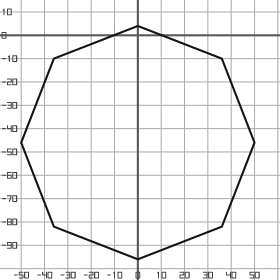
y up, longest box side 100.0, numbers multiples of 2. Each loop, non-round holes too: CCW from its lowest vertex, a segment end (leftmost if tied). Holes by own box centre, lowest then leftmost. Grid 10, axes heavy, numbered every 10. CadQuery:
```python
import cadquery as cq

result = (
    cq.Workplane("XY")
    .moveTo(0.0, -96.0)
    .lineTo(36.0, -82.0)
    .lineTo(50.0, -46.0)
    .lineTo(36.0, -10.0)
    .lineTo(0.0, 4.0)
    .lineTo(-36.0, -10.0)
    .lineTo(-50.0, -46.0)
    .lineTo(-36.0, -82.0)
    .close()
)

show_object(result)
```